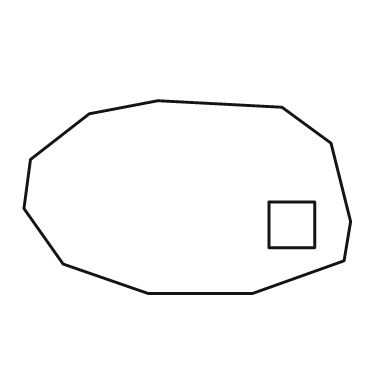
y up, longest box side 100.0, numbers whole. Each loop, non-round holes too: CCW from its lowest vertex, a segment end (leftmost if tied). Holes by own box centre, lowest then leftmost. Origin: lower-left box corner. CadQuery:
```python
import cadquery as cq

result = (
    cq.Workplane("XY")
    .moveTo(38.0, 0.0)
    .lineTo(70.0, 0.0)
    .lineTo(98.0, 10.0)
    .lineTo(100.0, 22.0)
    .lineTo(94.0, 46.0)
    .lineTo(79.0, 57.0)
    .lineTo(41.0, 59.0)
    .lineTo(20.0, 55.0)
    .lineTo(2.0, 41.0)
    .lineTo(0.0, 26.0)
    .lineTo(12.0, 9.0)
    .close()
    .moveTo(75.0, 14.0)
    .lineTo(89.0, 14.0)
    .lineTo(89.0, 28.0)
    .lineTo(75.0, 28.0)
    .close()
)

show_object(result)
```